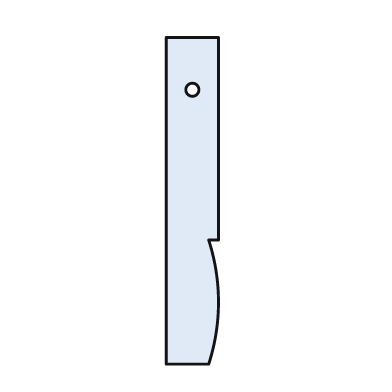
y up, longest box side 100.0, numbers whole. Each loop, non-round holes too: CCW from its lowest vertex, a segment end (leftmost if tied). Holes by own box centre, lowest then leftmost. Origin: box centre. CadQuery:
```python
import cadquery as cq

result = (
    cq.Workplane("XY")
    .moveTo(-8.0, -50.0)
    .lineTo(5.0, -50.0)
    .threePointArc((8.0, -31.0), (5.0, -12.0))
    .lineTo(8.0, -12.0)
    .lineTo(8.0, 50.0)
    .lineTo(-8.0, 50.0)
    .close()
    .moveTo(0.0, 34.0)
    .circle(2.0)
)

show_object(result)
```